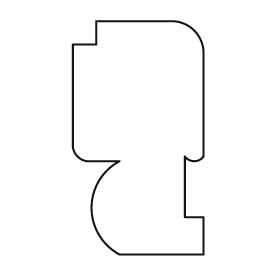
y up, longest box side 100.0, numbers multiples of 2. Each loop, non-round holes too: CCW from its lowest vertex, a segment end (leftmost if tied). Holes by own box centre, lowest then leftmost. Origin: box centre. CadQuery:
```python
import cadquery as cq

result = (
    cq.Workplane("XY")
    .moveTo(-8.0, -50.0)
    .lineTo(28.0, -50.0)
    .lineTo(28.0, -34.0)
    .lineTo(20.0, -34.0)
    .lineTo(20.0, -8.0)
    .threePointArc((24.0, -10.0), (28.0, -8.0))
    .lineTo(28.0, 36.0)
    .threePointArc((24.0, 46.0), (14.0, 50.0))
    .lineTo(-18.0, 50.0)
    .lineTo(-18.0, 40.0)
    .lineTo(-28.0, 40.0)
    .lineTo(-28.0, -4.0)
    .threePointArc((-26.0, -8.0), (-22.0, -10.0))
    .lineTo(-8.0, -10.0)
    .threePointArc((-20.0, -30.0), (-8.0, -50.0))
    .close()
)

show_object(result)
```